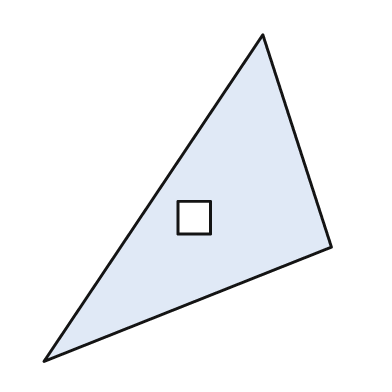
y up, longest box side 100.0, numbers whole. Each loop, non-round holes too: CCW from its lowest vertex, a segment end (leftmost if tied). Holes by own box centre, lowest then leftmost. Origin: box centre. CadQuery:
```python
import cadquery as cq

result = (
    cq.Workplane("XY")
    .moveTo(-44.0, -50.0)
    .lineTo(44.0, -15.0)
    .lineTo(23.0, 50.0)
    .close()
    .moveTo(-3.0, -11.0)
    .lineTo(7.0, -11.0)
    .lineTo(7.0, -1.0)
    .lineTo(-3.0, -1.0)
    .close()
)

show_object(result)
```